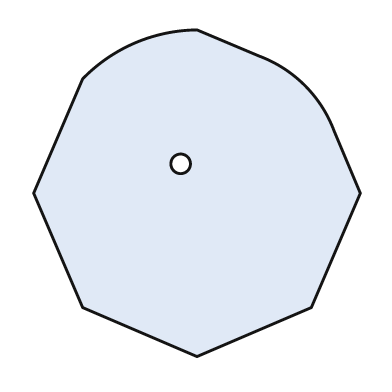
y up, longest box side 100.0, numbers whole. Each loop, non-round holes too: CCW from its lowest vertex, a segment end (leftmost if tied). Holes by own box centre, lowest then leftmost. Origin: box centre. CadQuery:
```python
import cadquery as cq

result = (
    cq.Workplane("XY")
    .moveTo(0.0, -50.0)
    .lineTo(35.0, -35.0)
    .lineTo(50.0, 0.0)
    .lineTo(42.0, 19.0)
    .threePointArc((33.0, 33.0), (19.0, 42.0))
    .lineTo(0.0, 50.0)
    .threePointArc((-19.0, 46.0), (-35.0, 35.0))
    .lineTo(-50.0, 0.0)
    .lineTo(-35.0, -35.0)
    .close()
    .moveTo(-5.0, 9.0)
    .circle(3.0)
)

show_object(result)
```